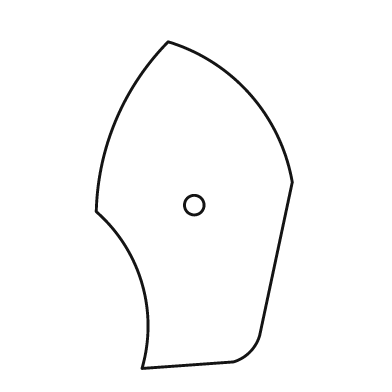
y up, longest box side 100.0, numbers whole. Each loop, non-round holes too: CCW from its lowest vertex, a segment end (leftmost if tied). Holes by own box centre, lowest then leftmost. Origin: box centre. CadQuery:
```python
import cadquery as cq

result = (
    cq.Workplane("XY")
    .moveTo(-16.0, -50.0)
    .lineTo(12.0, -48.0)
    .threePointArc((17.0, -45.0), (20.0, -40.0))
    .lineTo(30.0, 7.0)
    .threePointArc((17.0, 34.0), (-8.0, 50.0))
    .threePointArc((-24.0, 26.0), (-30.0, -2.0))
    .threePointArc((-16.0, -24.0), (-16.0, -50.0))
    .close()
    .moveTo(0.0, 0.0)
    .circle(3.0)
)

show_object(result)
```